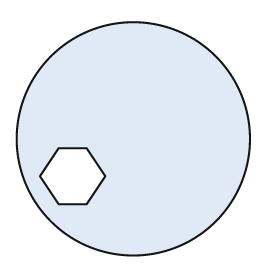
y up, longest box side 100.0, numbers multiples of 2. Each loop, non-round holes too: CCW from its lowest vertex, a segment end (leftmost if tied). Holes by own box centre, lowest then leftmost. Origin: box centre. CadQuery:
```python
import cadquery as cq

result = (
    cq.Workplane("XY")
    .moveTo(0.0, 0.0)
    .circle(50.0)
    .moveTo(-32.0, -28.0)
    .lineTo(-20.0, -28.0)
    .lineTo(-12.0, -16.0)
    .lineTo(-20.0, -4.0)
    .lineTo(-32.0, -4.0)
    .lineTo(-40.0, -16.0)
    .close()
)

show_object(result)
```